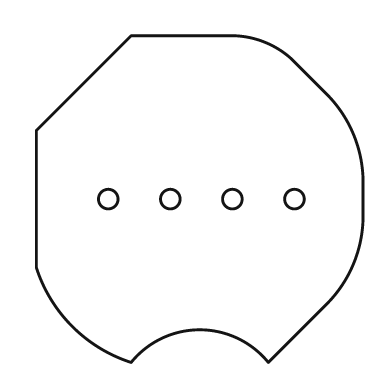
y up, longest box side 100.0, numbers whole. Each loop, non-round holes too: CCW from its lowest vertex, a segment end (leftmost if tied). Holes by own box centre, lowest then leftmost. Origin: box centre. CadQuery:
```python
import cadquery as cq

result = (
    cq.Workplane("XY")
    .moveTo(-21.0, -50.0)
    .threePointArc((0.0, -40.0), (21.0, -50.0))
    .lineTo(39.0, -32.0)
    .threePointArc((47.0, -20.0), (50.0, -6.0))
    .lineTo(50.0, 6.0)
    .threePointArc((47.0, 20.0), (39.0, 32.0))
    .lineTo(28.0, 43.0)
    .threePointArc((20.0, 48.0), (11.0, 50.0))
    .lineTo(-21.0, 50.0)
    .lineTo(-50.0, 21.0)
    .lineTo(-50.0, -21.0)
    .threePointArc((-39.0, -39.0), (-21.0, -50.0))
    .close()
    .moveTo(-28.0, 0.0)
    .circle(3.0)
    .moveTo(-9.0, 0.0)
    .circle(3.0)
    .moveTo(10.0, 0.0)
    .circle(3.0)
    .moveTo(29.0, 0.0)
    .circle(3.0)
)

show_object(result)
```